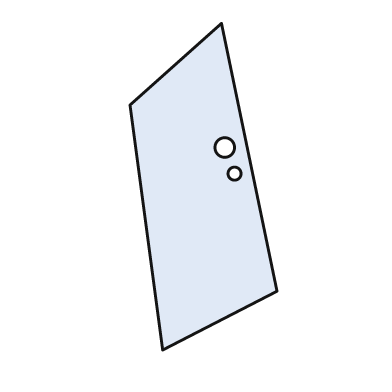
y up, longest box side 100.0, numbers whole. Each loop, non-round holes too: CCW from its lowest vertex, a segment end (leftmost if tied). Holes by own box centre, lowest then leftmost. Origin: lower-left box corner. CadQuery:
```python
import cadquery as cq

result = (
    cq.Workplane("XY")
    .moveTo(10.0, 0.0)
    .lineTo(45.0, 18.0)
    .lineTo(28.0, 100.0)
    .lineTo(0.0, 75.0)
    .close()
    .moveTo(32.0, 54.0)
    .circle(2.0)
    .moveTo(29.0, 62.0)
    .circle(3.0)
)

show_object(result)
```